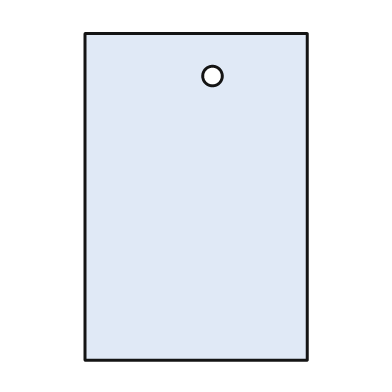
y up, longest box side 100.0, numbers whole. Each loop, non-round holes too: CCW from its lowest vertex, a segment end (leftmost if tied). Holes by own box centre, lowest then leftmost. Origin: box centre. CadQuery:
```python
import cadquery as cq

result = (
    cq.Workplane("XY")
    .moveTo(-34.0, -50.0)
    .lineTo(34.0, -50.0)
    .lineTo(34.0, 50.0)
    .lineTo(-34.0, 50.0)
    .close()
    .moveTo(5.0, 37.0)
    .circle(3.0)
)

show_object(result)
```